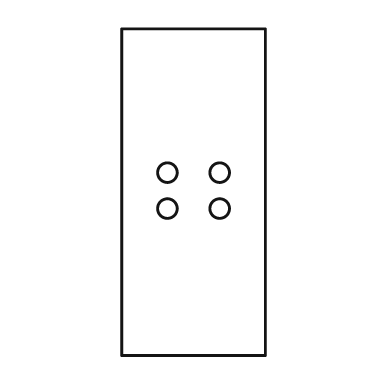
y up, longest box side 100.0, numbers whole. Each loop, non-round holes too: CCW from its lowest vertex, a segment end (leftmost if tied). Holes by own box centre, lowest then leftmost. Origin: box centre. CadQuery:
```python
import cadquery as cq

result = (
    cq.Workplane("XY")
    .moveTo(-22.0, -50.0)
    .lineTo(22.0, -50.0)
    .lineTo(22.0, 50.0)
    .lineTo(-22.0, 50.0)
    .close()
    .moveTo(-8.0, -5.0)
    .circle(3.0)
    .moveTo(8.0, -5.0)
    .circle(3.0)
    .moveTo(-8.0, 6.0)
    .circle(3.0)
    .moveTo(8.0, 6.0)
    .circle(3.0)
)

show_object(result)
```